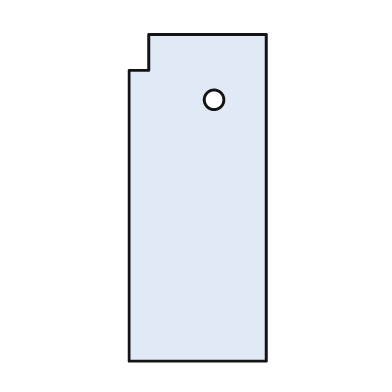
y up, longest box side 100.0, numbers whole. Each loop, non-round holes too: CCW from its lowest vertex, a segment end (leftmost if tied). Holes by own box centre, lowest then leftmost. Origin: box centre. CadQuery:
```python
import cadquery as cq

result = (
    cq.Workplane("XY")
    .moveTo(-21.0, -50.0)
    .lineTo(21.0, -50.0)
    .lineTo(21.0, 50.0)
    .lineTo(-15.0, 50.0)
    .lineTo(-15.0, 39.0)
    .lineTo(-21.0, 39.0)
    .close()
    .moveTo(5.0, 30.0)
    .circle(3.0)
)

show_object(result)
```